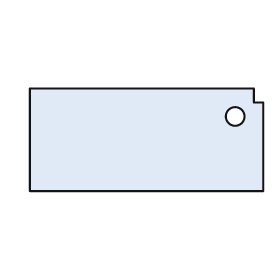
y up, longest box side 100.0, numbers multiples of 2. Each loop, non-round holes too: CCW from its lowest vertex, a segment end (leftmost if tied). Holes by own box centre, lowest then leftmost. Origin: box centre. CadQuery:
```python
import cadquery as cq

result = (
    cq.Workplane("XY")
    .moveTo(-50.0, -22.0)
    .lineTo(50.0, -22.0)
    .lineTo(50.0, 16.0)
    .lineTo(46.0, 16.0)
    .lineTo(46.0, 22.0)
    .lineTo(-50.0, 22.0)
    .close()
    .moveTo(38.0, 10.0)
    .circle(4.0)
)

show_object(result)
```